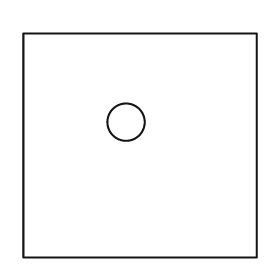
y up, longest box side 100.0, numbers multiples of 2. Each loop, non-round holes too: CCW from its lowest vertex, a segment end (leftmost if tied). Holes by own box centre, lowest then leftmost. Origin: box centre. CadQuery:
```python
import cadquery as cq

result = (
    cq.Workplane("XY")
    .moveTo(-50.0, -48.0)
    .lineTo(50.0, -48.0)
    .lineTo(50.0, 48.0)
    .lineTo(-50.0, 48.0)
    .close()
    .moveTo(-6.0, 10.0)
    .circle(8.0)
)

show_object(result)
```